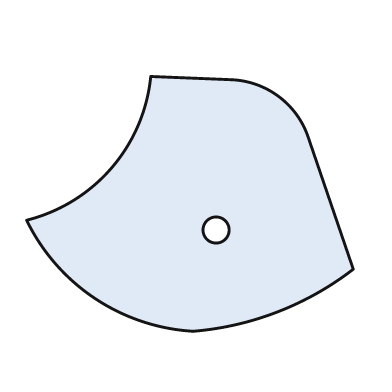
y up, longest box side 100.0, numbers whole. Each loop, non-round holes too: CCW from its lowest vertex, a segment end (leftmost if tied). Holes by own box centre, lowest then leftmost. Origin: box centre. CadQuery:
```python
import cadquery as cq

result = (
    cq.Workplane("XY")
    .moveTo(1.0, -39.0)
    .threePointArc((27.0, -33.0), (50.0, -20.0))
    .lineTo(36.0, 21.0)
    .threePointArc((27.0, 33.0), (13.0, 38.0))
    .lineTo(-12.0, 39.0)
    .threePointArc((-24.0, 11.0), (-50.0, -5.0))
    .threePointArc((-29.0, -29.0), (1.0, -39.0))
    .close()
    .moveTo(8.0, -8.0)
    .circle(4.0)
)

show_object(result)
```